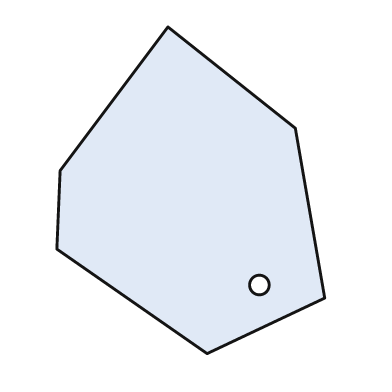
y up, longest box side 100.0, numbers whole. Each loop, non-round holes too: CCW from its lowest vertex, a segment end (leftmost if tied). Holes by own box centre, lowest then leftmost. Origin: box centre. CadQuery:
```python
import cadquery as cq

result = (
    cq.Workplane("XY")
    .moveTo(5.0, -50.0)
    .lineTo(41.0, -33.0)
    .lineTo(32.0, 19.0)
    .lineTo(-7.0, 50.0)
    .lineTo(-40.0, 6.0)
    .lineTo(-41.0, -18.0)
    .close()
    .moveTo(21.0, -29.0)
    .circle(3.0)
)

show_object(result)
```